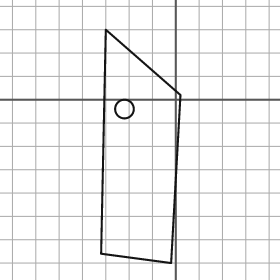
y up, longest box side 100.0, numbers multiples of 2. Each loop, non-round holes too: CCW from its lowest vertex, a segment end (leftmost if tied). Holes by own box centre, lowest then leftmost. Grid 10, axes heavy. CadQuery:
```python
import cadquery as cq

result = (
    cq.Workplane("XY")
    .moveTo(-2.0, -70.0)
    .lineTo(2.0, 2.0)
    .lineTo(-30.0, 30.0)
    .lineTo(-32.0, -66.0)
    .close()
    .moveTo(-22.0, -4.0)
    .circle(4.0)
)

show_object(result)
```